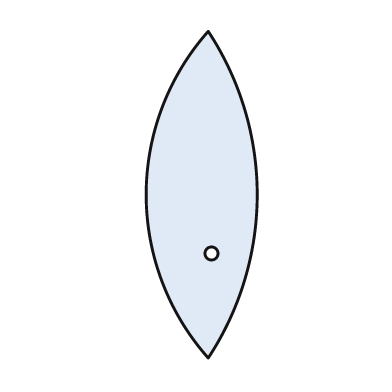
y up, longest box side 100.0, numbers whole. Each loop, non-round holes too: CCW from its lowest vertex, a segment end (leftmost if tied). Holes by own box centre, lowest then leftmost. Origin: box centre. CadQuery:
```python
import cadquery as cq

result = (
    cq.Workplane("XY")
    .moveTo(2.0, -50.0)
    .threePointArc((17.0, 0.0), (2.0, 50.0))
    .threePointArc((-17.0, 0.0), (2.0, -50.0))
    .close()
    .moveTo(3.0, -18.0)
    .circle(2.0)
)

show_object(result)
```